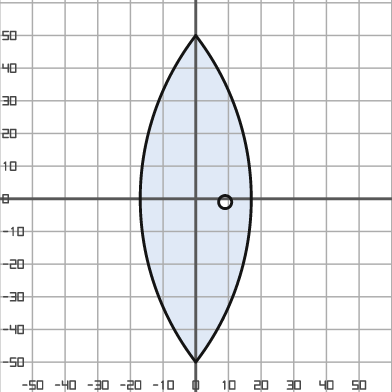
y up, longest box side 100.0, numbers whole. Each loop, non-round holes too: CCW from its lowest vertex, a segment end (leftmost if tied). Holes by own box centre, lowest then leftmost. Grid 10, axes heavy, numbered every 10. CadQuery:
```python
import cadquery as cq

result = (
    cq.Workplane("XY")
    .moveTo(0.0, -50.0)
    .threePointArc((17.0, 0.0), (0.0, 50.0))
    .threePointArc((-17.0, 0.0), (0.0, -50.0))
    .close()
    .moveTo(9.0, -1.0)
    .circle(2.0)
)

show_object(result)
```